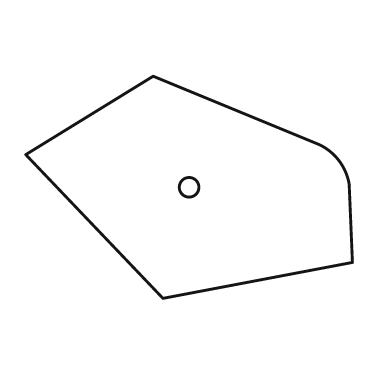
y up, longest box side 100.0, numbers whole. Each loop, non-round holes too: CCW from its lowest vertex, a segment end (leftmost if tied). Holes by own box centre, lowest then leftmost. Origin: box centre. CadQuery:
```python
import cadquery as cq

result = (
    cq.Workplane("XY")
    .moveTo(-8.0, -34.0)
    .lineTo(50.0, -23.0)
    .lineTo(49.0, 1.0)
    .threePointArc((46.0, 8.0), (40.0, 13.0))
    .lineTo(-11.0, 34.0)
    .lineTo(-50.0, 10.0)
    .close()
    .moveTo(0.0, 0.0)
    .circle(3.0)
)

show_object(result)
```